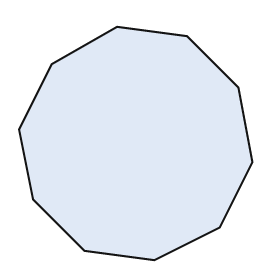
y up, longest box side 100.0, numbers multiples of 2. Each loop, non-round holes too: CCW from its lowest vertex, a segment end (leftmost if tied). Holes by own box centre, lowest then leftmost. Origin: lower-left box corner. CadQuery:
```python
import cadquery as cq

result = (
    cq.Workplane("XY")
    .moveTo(58.0, 0.0)
    .lineTo(86.0, 14.0)
    .lineTo(100.0, 42.0)
    .lineTo(94.0, 74.0)
    .lineTo(72.0, 96.0)
    .lineTo(42.0, 100.0)
    .lineTo(14.0, 84.0)
    .lineTo(0.0, 56.0)
    .lineTo(6.0, 26.0)
    .lineTo(28.0, 4.0)
    .close()
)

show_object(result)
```